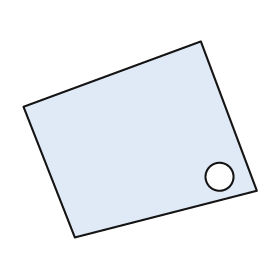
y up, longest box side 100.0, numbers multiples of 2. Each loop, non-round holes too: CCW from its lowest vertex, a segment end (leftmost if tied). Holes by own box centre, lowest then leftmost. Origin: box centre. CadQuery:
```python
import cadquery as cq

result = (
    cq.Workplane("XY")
    .moveTo(-28.0, -42.0)
    .lineTo(50.0, -22.0)
    .lineTo(26.0, 42.0)
    .lineTo(-50.0, 14.0)
    .close()
    .moveTo(34.0, -16.0)
    .circle(6.0)
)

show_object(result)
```